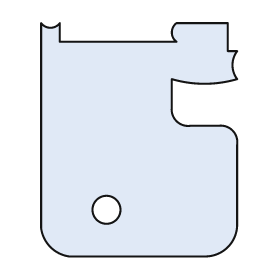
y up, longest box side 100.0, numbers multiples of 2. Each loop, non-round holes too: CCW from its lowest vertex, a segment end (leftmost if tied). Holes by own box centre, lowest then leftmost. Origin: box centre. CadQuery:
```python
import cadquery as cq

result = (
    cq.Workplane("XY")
    .moveTo(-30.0, -50.0)
    .lineTo(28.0, -50.0)
    .threePointArc((38.0, -46.0), (42.0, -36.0))
    .lineTo(42.0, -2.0)
    .threePointArc((40.0, 4.0), (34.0, 6.0))
    .lineTo(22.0, 6.0)
    .threePointArc((16.0, 8.0), (14.0, 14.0))
    .lineTo(14.0, 26.0)
    .threePointArc((28.0, 24.0), (42.0, 26.0))
    .threePointArc((40.0, 32.0), (42.0, 38.0))
    .lineTo(38.0, 38.0)
    .lineTo(38.0, 50.0)
    .lineTo(16.0, 50.0)
    .threePointArc((14.0, 46.0), (16.0, 42.0))
    .lineTo(-34.0, 42.0)
    .lineTo(-34.0, 50.0)
    .threePointArc((-38.0, 48.0), (-42.0, 50.0))
    .lineTo(-42.0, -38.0)
    .threePointArc((-38.0, -46.0), (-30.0, -50.0))
    .close()
    .moveTo(-14.0, -30.0)
    .circle(6.0)
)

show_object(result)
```